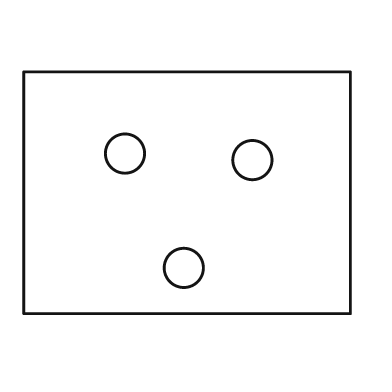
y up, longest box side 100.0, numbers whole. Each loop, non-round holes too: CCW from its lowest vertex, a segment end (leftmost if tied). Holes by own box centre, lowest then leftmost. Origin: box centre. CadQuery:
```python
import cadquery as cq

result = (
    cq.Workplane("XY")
    .moveTo(-50.0, -37.0)
    .lineTo(50.0, -37.0)
    .lineTo(50.0, 37.0)
    .lineTo(-50.0, 37.0)
    .close()
    .moveTo(-1.0, -23.0)
    .circle(6.0)
    .moveTo(20.0, 10.0)
    .circle(6.0)
    .moveTo(-19.0, 12.0)
    .circle(6.0)
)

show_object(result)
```